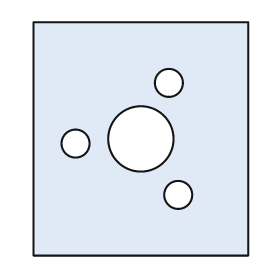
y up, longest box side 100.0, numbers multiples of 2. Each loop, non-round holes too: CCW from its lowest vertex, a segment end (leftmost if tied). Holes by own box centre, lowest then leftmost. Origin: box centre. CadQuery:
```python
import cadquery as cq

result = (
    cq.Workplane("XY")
    .moveTo(-46.0, -50.0)
    .lineTo(46.0, -50.0)
    .lineTo(46.0, 50.0)
    .lineTo(-46.0, 50.0)
    .close()
    .moveTo(16.0, -24.0)
    .circle(6.0)
    .moveTo(-28.0, -2.0)
    .circle(6.0)
    .moveTo(0.0, 0.0)
    .circle(14.0)
    .moveTo(12.0, 24.0)
    .circle(6.0)
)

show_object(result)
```